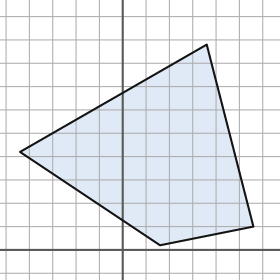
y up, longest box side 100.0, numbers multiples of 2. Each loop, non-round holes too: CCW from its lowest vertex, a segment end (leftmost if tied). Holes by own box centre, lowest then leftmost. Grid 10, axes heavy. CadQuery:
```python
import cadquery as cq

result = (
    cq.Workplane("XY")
    .moveTo(16.0, 2.0)
    .lineTo(56.0, 10.0)
    .lineTo(36.0, 88.0)
    .lineTo(-44.0, 42.0)
    .close()
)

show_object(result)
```